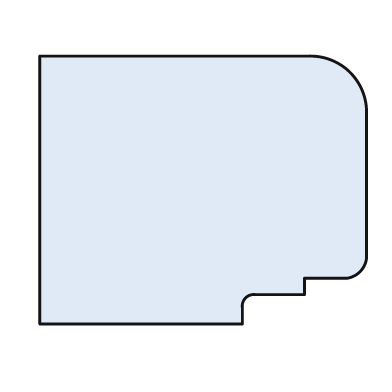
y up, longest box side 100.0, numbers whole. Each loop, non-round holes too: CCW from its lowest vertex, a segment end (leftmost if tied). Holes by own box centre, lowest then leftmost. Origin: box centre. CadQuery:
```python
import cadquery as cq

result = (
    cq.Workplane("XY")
    .moveTo(-50.0, -41.0)
    .lineTo(12.0, -41.0)
    .lineTo(12.0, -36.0)
    .threePointArc((13.0, -33.0), (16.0, -32.0))
    .lineTo(31.0, -32.0)
    .lineTo(31.0, -27.0)
    .lineTo(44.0, -27.0)
    .threePointArc((48.0, -25.0), (50.0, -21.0))
    .lineTo(50.0, 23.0)
    .threePointArc((45.0, 36.0), (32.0, 41.0))
    .lineTo(-50.0, 41.0)
    .close()
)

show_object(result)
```